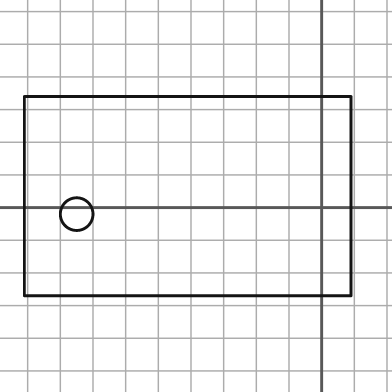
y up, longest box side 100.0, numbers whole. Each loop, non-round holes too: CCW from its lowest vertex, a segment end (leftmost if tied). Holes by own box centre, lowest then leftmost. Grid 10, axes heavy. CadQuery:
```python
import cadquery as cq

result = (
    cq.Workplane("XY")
    .moveTo(-91.0, -27.0)
    .lineTo(9.0, -27.0)
    .lineTo(9.0, 34.0)
    .lineTo(-91.0, 34.0)
    .close()
    .moveTo(-75.0, -2.0)
    .circle(5.0)
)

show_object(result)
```